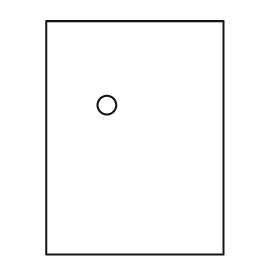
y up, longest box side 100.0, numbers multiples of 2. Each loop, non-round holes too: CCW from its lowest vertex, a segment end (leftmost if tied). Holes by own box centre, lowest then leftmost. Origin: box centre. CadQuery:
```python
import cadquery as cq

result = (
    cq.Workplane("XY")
    .moveTo(-38.0, -50.0)
    .lineTo(38.0, -50.0)
    .lineTo(38.0, 50.0)
    .lineTo(-38.0, 50.0)
    .close()
    .moveTo(-12.0, 14.0)
    .circle(4.0)
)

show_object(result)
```